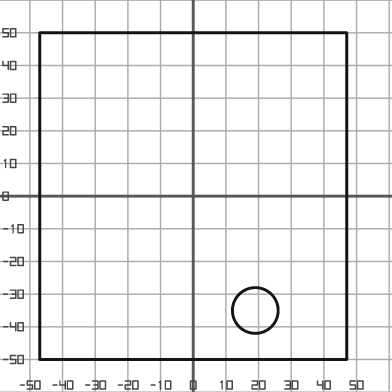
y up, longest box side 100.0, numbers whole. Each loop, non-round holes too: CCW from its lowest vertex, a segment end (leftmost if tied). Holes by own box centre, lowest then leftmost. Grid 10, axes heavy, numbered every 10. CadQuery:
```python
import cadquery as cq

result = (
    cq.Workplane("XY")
    .moveTo(-47.0, -50.0)
    .lineTo(47.0, -50.0)
    .lineTo(47.0, 50.0)
    .lineTo(-47.0, 50.0)
    .close()
    .moveTo(19.0, -35.0)
    .circle(7.0)
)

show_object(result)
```